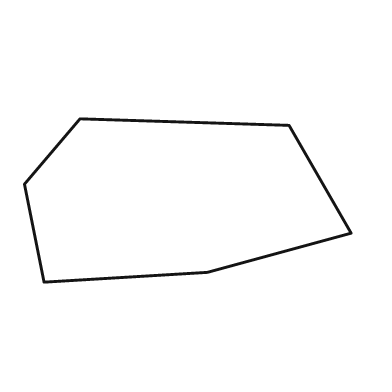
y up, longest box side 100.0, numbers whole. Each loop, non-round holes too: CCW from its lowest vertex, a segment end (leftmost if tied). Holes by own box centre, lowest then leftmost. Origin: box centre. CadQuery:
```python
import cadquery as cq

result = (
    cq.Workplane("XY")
    .moveTo(-44.0, -25.0)
    .lineTo(6.0, -22.0)
    .lineTo(50.0, -10.0)
    .lineTo(31.0, 23.0)
    .lineTo(-33.0, 25.0)
    .lineTo(-50.0, 5.0)
    .close()
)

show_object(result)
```